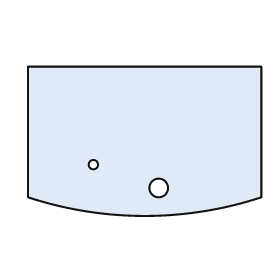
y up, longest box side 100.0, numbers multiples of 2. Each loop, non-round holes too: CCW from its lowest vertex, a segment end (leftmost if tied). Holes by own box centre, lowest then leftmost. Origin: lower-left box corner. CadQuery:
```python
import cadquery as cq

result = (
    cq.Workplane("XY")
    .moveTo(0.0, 8.0)
    .threePointArc((50.0, 0.0), (100.0, 8.0))
    .lineTo(100.0, 64.0)
    .lineTo(0.0, 64.0)
    .close()
    .moveTo(56.0, 12.0)
    .circle(4.0)
    .moveTo(28.0, 22.0)
    .circle(2.0)
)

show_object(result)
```